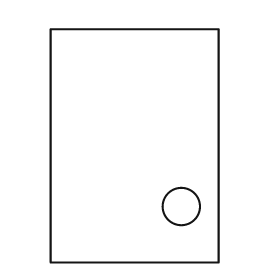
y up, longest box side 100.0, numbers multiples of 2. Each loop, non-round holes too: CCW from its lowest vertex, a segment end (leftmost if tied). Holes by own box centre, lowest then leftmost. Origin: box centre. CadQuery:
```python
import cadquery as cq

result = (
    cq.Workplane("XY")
    .moveTo(-36.0, -50.0)
    .lineTo(36.0, -50.0)
    .lineTo(36.0, 50.0)
    .lineTo(-36.0, 50.0)
    .close()
    .moveTo(20.0, -26.0)
    .circle(8.0)
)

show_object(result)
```